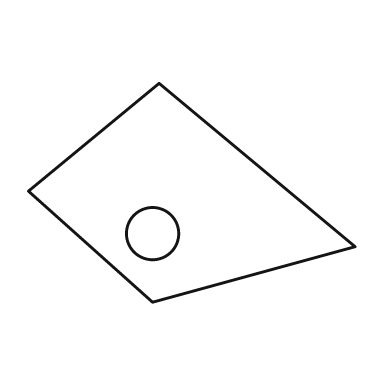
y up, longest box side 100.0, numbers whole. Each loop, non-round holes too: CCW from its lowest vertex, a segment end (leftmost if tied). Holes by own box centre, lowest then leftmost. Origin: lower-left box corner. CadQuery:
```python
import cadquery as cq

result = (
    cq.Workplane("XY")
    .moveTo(38.0, 0.0)
    .lineTo(100.0, 17.0)
    .lineTo(40.0, 67.0)
    .lineTo(0.0, 34.0)
    .close()
    .moveTo(38.0, 21.0)
    .circle(8.0)
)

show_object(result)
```